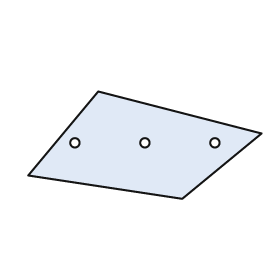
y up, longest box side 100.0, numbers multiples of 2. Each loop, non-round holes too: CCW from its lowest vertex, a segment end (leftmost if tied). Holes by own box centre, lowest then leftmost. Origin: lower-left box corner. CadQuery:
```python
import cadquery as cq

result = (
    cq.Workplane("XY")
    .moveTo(66.0, 0.0)
    .lineTo(100.0, 28.0)
    .lineTo(30.0, 46.0)
    .lineTo(0.0, 10.0)
    .close()
    .moveTo(20.0, 24.0)
    .circle(2.0)
    .moveTo(50.0, 24.0)
    .circle(2.0)
    .moveTo(80.0, 24.0)
    .circle(2.0)
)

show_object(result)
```